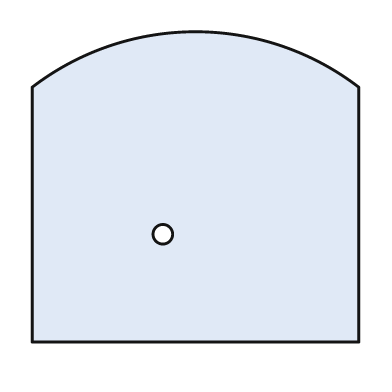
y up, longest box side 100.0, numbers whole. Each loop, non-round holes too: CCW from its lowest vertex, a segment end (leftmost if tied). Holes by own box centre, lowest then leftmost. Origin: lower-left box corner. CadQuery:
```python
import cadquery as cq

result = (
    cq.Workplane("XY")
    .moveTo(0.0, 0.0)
    .lineTo(100.0, 0.0)
    .lineTo(100.0, 78.0)
    .threePointArc((50.0, 95.0), (0.0, 78.0))
    .close()
    .moveTo(40.0, 33.0)
    .circle(3.0)
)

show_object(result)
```